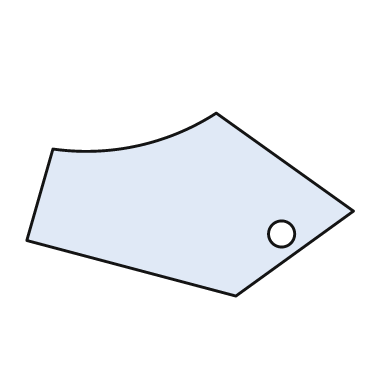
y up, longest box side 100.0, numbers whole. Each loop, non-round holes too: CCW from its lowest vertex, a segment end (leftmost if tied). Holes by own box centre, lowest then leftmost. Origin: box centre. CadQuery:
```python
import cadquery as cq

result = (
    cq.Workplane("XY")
    .moveTo(14.0, -28.0)
    .lineTo(50.0, -2.0)
    .lineTo(8.0, 28.0)
    .threePointArc((-16.0, 18.0), (-42.0, 17.0))
    .lineTo(-50.0, -11.0)
    .close()
    .moveTo(28.0, -9.0)
    .circle(4.0)
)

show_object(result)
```